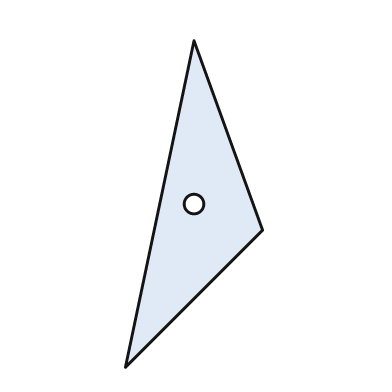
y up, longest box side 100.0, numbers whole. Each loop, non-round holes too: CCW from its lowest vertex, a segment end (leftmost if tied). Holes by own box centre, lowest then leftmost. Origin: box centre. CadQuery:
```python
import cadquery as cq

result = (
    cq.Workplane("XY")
    .moveTo(-21.0, -50.0)
    .lineTo(21.0, -8.0)
    .lineTo(0.0, 50.0)
    .close()
    .moveTo(0.0, 0.0)
    .circle(3.0)
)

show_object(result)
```